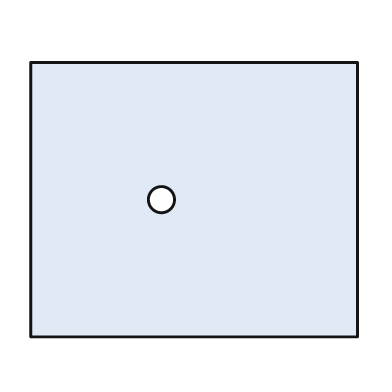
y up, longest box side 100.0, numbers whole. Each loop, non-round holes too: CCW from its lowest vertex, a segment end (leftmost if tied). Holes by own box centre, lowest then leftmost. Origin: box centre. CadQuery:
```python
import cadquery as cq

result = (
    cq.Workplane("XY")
    .moveTo(-50.0, -42.0)
    .lineTo(50.0, -42.0)
    .lineTo(50.0, 42.0)
    .lineTo(-50.0, 42.0)
    .close()
    .moveTo(-10.0, 0.0)
    .circle(4.0)
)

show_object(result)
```